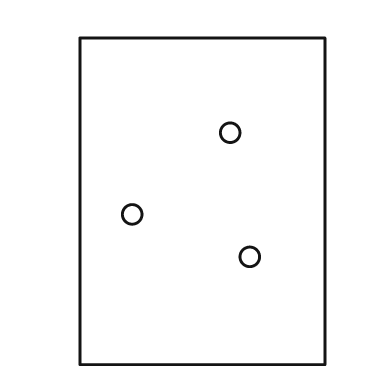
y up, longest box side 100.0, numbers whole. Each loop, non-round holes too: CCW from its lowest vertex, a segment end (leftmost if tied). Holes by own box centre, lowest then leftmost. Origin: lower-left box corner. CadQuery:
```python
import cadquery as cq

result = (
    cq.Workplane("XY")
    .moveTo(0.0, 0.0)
    .lineTo(75.0, 0.0)
    .lineTo(75.0, 100.0)
    .lineTo(0.0, 100.0)
    .close()
    .moveTo(52.0, 33.0)
    .circle(3.0)
    .moveTo(16.0, 46.0)
    .circle(3.0)
    .moveTo(46.0, 71.0)
    .circle(3.0)
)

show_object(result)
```